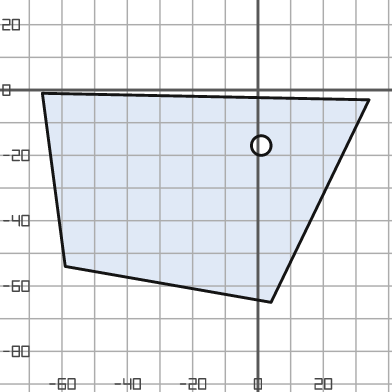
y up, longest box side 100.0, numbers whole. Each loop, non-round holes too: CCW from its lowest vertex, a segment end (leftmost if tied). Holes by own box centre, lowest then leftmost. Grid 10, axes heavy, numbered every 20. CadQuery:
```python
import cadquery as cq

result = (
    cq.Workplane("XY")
    .moveTo(4.0, -65.0)
    .lineTo(34.0, -3.0)
    .lineTo(-66.0, -1.0)
    .lineTo(-59.0, -54.0)
    .close()
    .moveTo(1.0, -17.0)
    .circle(3.0)
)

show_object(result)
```